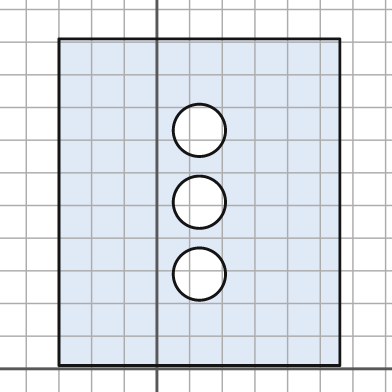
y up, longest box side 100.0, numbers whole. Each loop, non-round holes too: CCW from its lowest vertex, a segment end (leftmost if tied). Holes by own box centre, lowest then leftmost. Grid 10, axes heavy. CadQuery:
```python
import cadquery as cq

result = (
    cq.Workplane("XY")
    .moveTo(-30.0, 1.0)
    .lineTo(56.0, 1.0)
    .lineTo(56.0, 101.0)
    .lineTo(-30.0, 101.0)
    .close()
    .moveTo(13.0, 29.0)
    .circle(8.0)
    .moveTo(13.0, 51.0)
    .circle(8.0)
    .moveTo(13.0, 73.0)
    .circle(8.0)
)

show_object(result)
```